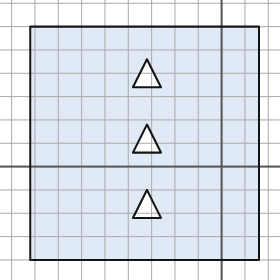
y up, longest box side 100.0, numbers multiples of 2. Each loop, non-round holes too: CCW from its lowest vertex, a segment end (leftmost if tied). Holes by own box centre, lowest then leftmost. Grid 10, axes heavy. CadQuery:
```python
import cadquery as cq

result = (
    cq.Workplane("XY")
    .moveTo(-82.0, -40.0)
    .lineTo(16.0, -40.0)
    .lineTo(16.0, 60.0)
    .lineTo(-82.0, 60.0)
    .close()
    .moveTo(-38.0, -22.0)
    .lineTo(-26.0, -22.0)
    .lineTo(-32.0, -10.0)
    .close()
    .moveTo(-38.0, 6.0)
    .lineTo(-26.0, 6.0)
    .lineTo(-32.0, 18.0)
    .close()
    .moveTo(-38.0, 34.0)
    .lineTo(-26.0, 34.0)
    .lineTo(-32.0, 46.0)
    .close()
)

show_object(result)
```